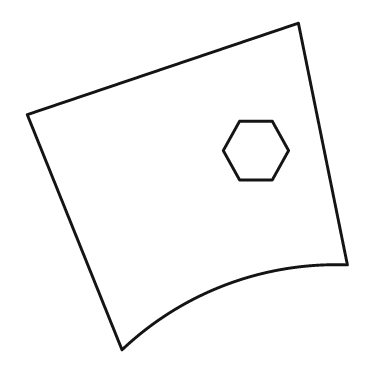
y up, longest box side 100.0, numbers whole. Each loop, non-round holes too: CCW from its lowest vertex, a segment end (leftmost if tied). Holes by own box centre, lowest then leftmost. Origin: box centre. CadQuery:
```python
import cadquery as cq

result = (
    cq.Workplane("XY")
    .moveTo(-20.0, -50.0)
    .threePointArc((12.0, -30.0), (49.0, -24.0))
    .lineTo(34.0, 50.0)
    .lineTo(-49.0, 22.0)
    .close()
    .moveTo(16.0, 2.0)
    .lineTo(26.0, 2.0)
    .lineTo(31.0, 11.0)
    .lineTo(26.0, 20.0)
    .lineTo(16.0, 20.0)
    .lineTo(11.0, 11.0)
    .close()
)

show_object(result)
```